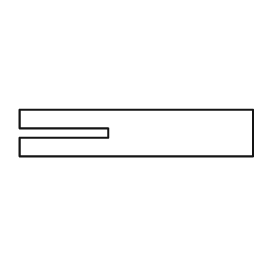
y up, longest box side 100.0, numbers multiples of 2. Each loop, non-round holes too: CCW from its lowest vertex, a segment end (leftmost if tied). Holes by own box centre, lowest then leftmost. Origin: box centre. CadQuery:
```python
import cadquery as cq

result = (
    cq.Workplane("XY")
    .moveTo(-50.0, -10.0)
    .lineTo(50.0, -10.0)
    .lineTo(50.0, 10.0)
    .lineTo(-50.0, 10.0)
    .lineTo(-50.0, 2.0)
    .lineTo(-12.0, 2.0)
    .lineTo(-12.0, -2.0)
    .lineTo(-50.0, -2.0)
    .close()
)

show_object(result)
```